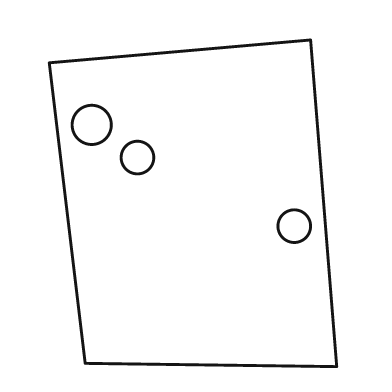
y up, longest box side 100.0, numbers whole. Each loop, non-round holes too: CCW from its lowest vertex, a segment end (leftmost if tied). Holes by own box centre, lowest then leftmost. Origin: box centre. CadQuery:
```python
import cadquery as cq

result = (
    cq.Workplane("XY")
    .moveTo(44.0, -50.0)
    .lineTo(36.0, 50.0)
    .lineTo(-44.0, 43.0)
    .lineTo(-33.0, -49.0)
    .close()
    .moveTo(31.0, -7.0)
    .circle(5.0)
    .moveTo(-17.0, 14.0)
    .circle(5.0)
    .moveTo(-31.0, 24.0)
    .circle(6.0)
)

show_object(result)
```